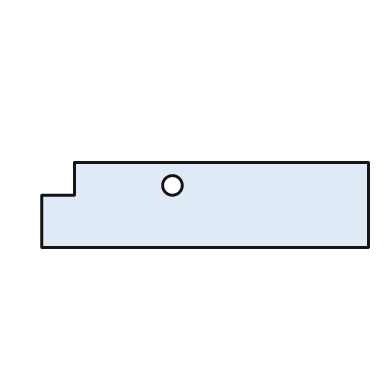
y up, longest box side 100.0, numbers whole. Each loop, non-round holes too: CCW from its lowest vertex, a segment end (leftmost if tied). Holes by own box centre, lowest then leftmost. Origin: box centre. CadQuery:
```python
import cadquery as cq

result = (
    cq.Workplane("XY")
    .moveTo(-50.0, -13.0)
    .lineTo(50.0, -13.0)
    .lineTo(50.0, 13.0)
    .lineTo(-40.0, 13.0)
    .lineTo(-40.0, 3.0)
    .lineTo(-50.0, 3.0)
    .close()
    .moveTo(-10.0, 6.0)
    .circle(3.0)
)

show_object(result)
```